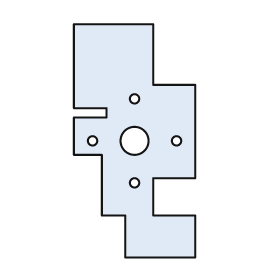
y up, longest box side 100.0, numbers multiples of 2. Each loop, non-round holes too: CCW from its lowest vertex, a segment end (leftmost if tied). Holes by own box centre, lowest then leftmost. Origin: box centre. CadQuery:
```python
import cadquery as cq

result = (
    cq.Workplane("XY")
    .moveTo(-4.0, -50.0)
    .lineTo(26.0, -50.0)
    .lineTo(26.0, -32.0)
    .lineTo(8.0, -32.0)
    .lineTo(8.0, -16.0)
    .lineTo(26.0, -16.0)
    .lineTo(26.0, 24.0)
    .lineTo(8.0, 24.0)
    .lineTo(8.0, 50.0)
    .lineTo(-26.0, 50.0)
    .lineTo(-26.0, 14.0)
    .lineTo(-12.0, 14.0)
    .lineTo(-12.0, 10.0)
    .lineTo(-26.0, 10.0)
    .lineTo(-26.0, -6.0)
    .lineTo(-14.0, -6.0)
    .lineTo(-14.0, -32.0)
    .lineTo(-4.0, -32.0)
    .close()
    .moveTo(0.0, -18.0)
    .circle(2.0)
    .moveTo(-18.0, 0.0)
    .circle(2.0)
    .moveTo(0.0, 0.0)
    .circle(6.0)
    .moveTo(18.0, 0.0)
    .circle(2.0)
    .moveTo(0.0, 18.0)
    .circle(2.0)
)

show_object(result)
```